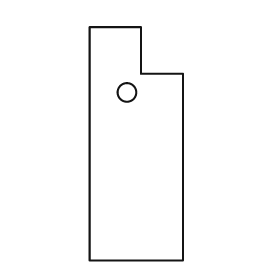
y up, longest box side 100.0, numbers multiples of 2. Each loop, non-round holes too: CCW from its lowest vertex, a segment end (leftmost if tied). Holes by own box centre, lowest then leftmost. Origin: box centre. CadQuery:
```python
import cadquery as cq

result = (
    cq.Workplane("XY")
    .moveTo(-20.0, -50.0)
    .lineTo(20.0, -50.0)
    .lineTo(20.0, 30.0)
    .lineTo(2.0, 30.0)
    .lineTo(2.0, 50.0)
    .lineTo(-20.0, 50.0)
    .close()
    .moveTo(-4.0, 22.0)
    .circle(4.0)
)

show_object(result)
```